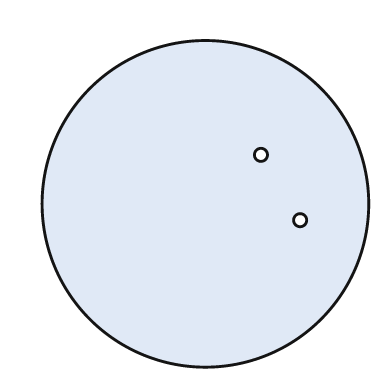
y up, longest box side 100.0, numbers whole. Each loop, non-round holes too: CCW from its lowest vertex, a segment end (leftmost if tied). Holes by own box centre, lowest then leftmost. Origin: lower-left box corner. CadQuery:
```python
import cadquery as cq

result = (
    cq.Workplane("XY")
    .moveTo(50.0, 50.0)
    .circle(50.0)
    .moveTo(79.0, 45.0)
    .circle(2.0)
    .moveTo(67.0, 65.0)
    .circle(2.0)
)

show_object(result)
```